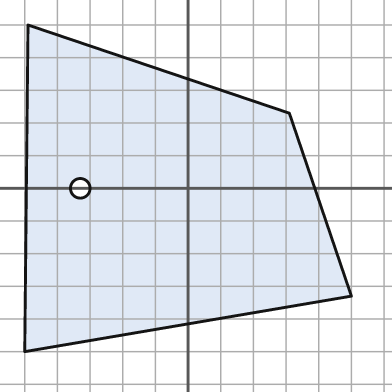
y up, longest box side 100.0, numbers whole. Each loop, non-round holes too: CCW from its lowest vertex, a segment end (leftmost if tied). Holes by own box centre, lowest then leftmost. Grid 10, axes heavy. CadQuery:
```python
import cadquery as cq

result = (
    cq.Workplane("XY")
    .moveTo(-50.0, -50.0)
    .lineTo(50.0, -33.0)
    .lineTo(31.0, 23.0)
    .lineTo(-49.0, 50.0)
    .close()
    .moveTo(-33.0, 0.0)
    .circle(3.0)
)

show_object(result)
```